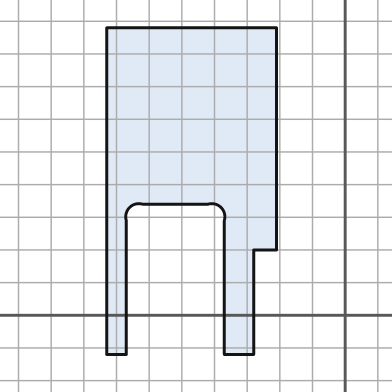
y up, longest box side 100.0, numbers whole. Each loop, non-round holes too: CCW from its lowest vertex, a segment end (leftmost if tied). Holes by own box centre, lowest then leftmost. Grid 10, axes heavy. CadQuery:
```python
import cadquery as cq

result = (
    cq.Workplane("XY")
    .moveTo(-73.0, -12.0)
    .lineTo(-67.0, -12.0)
    .lineTo(-67.0, 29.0)
    .threePointArc((-66.0, 33.0), (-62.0, 34.0))
    .lineTo(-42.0, 34.0)
    .threePointArc((-38.0, 33.0), (-37.0, 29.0))
    .lineTo(-37.0, -12.0)
    .lineTo(-28.0, -12.0)
    .lineTo(-28.0, 20.0)
    .lineTo(-21.0, 20.0)
    .lineTo(-21.0, 88.0)
    .lineTo(-73.0, 88.0)
    .close()
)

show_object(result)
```